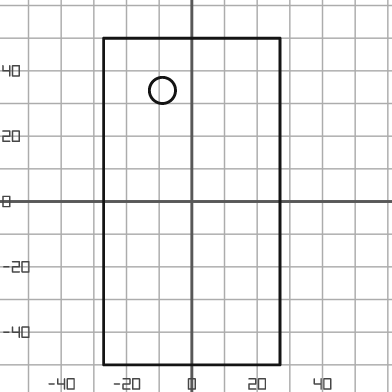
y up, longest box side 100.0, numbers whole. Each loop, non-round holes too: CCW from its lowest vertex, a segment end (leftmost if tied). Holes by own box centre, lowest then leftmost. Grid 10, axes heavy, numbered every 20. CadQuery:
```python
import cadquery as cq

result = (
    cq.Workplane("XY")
    .moveTo(-27.0, -50.0)
    .lineTo(27.0, -50.0)
    .lineTo(27.0, 50.0)
    .lineTo(-27.0, 50.0)
    .close()
    .moveTo(-9.0, 34.0)
    .circle(4.0)
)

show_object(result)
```